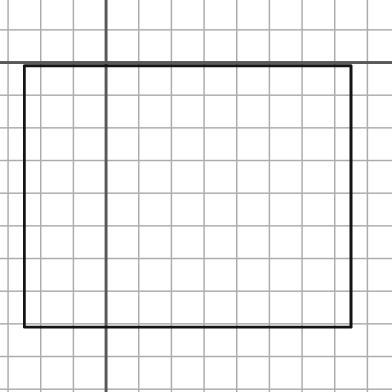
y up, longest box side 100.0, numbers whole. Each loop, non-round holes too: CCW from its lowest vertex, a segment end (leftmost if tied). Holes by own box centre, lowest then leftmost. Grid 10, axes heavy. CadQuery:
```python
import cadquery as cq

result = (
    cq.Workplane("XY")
    .moveTo(-25.0, -81.0)
    .lineTo(75.0, -81.0)
    .lineTo(75.0, -1.0)
    .lineTo(-25.0, -1.0)
    .close()
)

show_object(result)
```